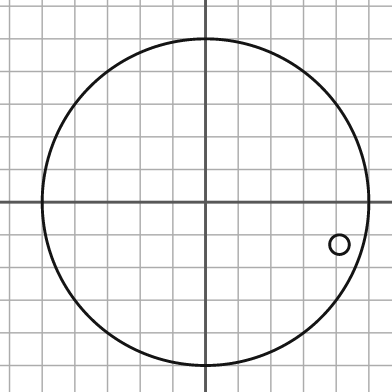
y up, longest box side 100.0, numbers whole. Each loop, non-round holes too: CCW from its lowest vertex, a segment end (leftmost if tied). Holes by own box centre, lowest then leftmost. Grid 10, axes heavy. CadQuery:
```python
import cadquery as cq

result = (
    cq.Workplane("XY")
    .moveTo(0.0, 0.0)
    .circle(50.0)
    .moveTo(41.0, -13.0)
    .circle(3.0)
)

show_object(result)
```